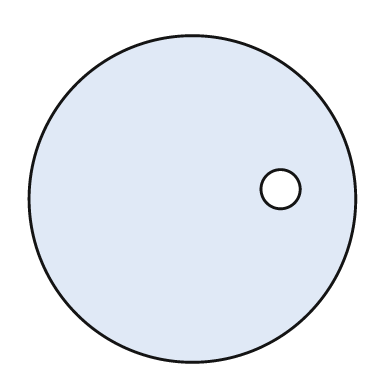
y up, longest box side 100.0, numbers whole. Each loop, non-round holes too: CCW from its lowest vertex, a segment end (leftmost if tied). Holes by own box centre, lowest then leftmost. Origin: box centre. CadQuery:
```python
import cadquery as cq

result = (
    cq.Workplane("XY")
    .moveTo(0.0, 0.0)
    .circle(50.0)
    .moveTo(27.0, 3.0)
    .circle(6.0)
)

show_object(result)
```